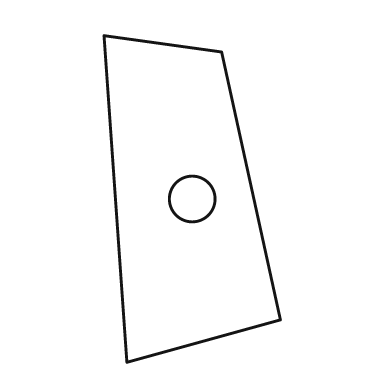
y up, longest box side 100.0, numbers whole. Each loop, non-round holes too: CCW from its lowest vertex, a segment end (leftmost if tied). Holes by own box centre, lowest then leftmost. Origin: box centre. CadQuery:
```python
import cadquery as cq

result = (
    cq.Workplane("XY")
    .moveTo(-20.0, -50.0)
    .lineTo(27.0, -37.0)
    .lineTo(9.0, 45.0)
    .lineTo(-27.0, 50.0)
    .close()
    .moveTo(0.0, 0.0)
    .circle(7.0)
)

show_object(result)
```